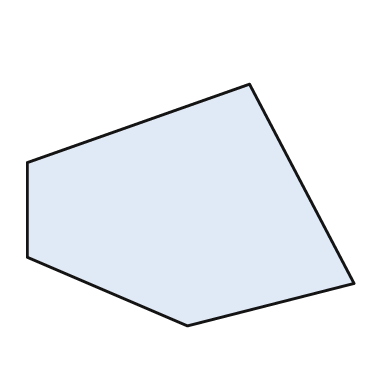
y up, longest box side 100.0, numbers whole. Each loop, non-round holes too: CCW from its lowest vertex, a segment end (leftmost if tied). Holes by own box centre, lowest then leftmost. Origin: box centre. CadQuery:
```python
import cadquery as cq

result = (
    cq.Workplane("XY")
    .moveTo(-1.0, -37.0)
    .lineTo(50.0, -24.0)
    .lineTo(18.0, 37.0)
    .lineTo(-50.0, 13.0)
    .lineTo(-50.0, -16.0)
    .close()
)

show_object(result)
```